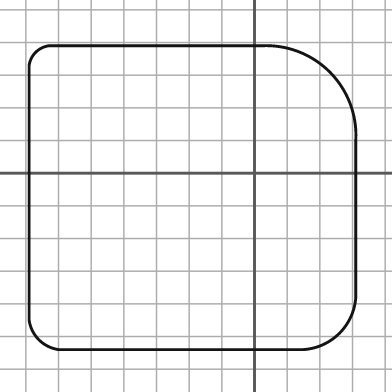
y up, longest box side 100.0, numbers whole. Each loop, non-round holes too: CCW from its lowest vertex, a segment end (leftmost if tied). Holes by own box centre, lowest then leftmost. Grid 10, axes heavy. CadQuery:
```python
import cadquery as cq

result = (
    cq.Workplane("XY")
    .moveTo(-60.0, -54.0)
    .lineTo(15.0, -54.0)
    .threePointArc((26.0, -49.0), (31.0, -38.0))
    .lineTo(31.0, 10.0)
    .threePointArc((23.0, 31.0), (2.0, 39.0))
    .lineTo(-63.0, 39.0)
    .threePointArc((-67.0, 37.0), (-69.0, 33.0))
    .lineTo(-69.0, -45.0)
    .threePointArc((-66.0, -51.0), (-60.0, -54.0))
    .close()
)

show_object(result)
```